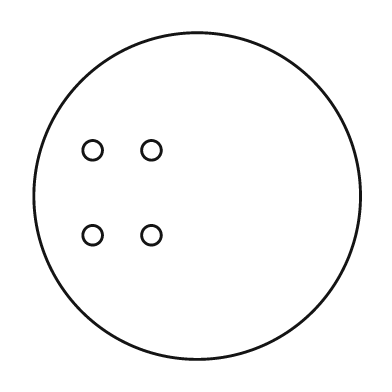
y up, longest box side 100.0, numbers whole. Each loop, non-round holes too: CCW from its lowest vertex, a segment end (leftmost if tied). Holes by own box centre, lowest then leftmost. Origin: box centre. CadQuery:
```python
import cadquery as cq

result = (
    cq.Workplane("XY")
    .moveTo(0.0, 0.0)
    .circle(50.0)
    .moveTo(-32.0, -12.0)
    .circle(3.0)
    .moveTo(-14.0, -12.0)
    .circle(3.0)
    .moveTo(-32.0, 14.0)
    .circle(3.0)
    .moveTo(-14.0, 14.0)
    .circle(3.0)
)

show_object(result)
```